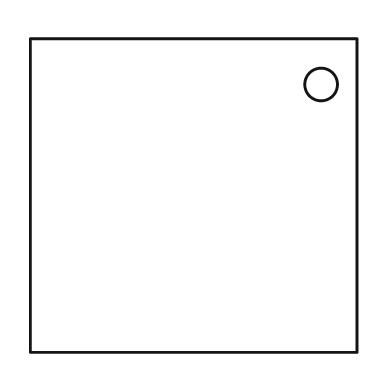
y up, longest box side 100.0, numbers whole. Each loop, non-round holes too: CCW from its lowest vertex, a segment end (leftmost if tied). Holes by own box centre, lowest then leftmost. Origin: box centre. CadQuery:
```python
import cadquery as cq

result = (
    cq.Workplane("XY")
    .moveTo(-50.0, -48.0)
    .lineTo(50.0, -48.0)
    .lineTo(50.0, 48.0)
    .lineTo(-50.0, 48.0)
    .close()
    .moveTo(39.0, 34.0)
    .circle(5.0)
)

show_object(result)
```